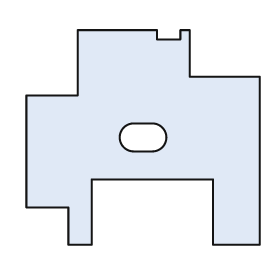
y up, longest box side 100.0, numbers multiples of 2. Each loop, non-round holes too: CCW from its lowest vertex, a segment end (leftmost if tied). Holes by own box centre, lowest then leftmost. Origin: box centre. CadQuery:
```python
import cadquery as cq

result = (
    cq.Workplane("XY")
    .moveTo(-32.0, -46.0)
    .lineTo(-22.0, -46.0)
    .lineTo(-22.0, -18.0)
    .lineTo(30.0, -18.0)
    .lineTo(30.0, -46.0)
    .lineTo(50.0, -46.0)
    .lineTo(50.0, 26.0)
    .lineTo(20.0, 26.0)
    .lineTo(20.0, 46.0)
    .lineTo(16.0, 46.0)
    .lineTo(16.0, 42.0)
    .lineTo(6.0, 42.0)
    .lineTo(6.0, 46.0)
    .lineTo(-28.0, 46.0)
    .lineTo(-28.0, 18.0)
    .lineTo(-50.0, 18.0)
    .lineTo(-50.0, -30.0)
    .lineTo(-32.0, -30.0)
    .close()
    .moveTo(-4.0, -6.0)
    .lineTo(4.0, -6.0)
    .threePointArc((10.0, 0.0), (4.0, 6.0))
    .lineTo(-4.0, 6.0)
    .threePointArc((-10.0, 0.0), (-4.0, -6.0))
    .close()
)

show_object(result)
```